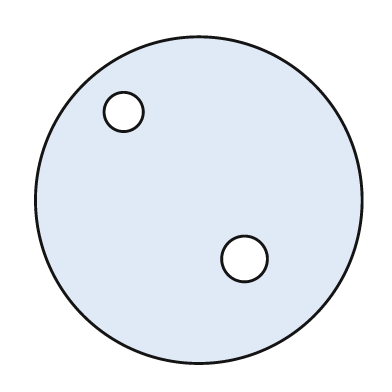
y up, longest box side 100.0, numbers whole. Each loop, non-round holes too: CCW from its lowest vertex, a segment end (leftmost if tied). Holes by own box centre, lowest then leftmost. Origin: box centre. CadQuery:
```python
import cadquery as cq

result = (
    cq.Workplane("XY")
    .moveTo(0.0, 0.0)
    .circle(50.0)
    .moveTo(14.0, -18.0)
    .circle(7.0)
    .moveTo(-23.0, 27.0)
    .circle(6.0)
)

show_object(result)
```